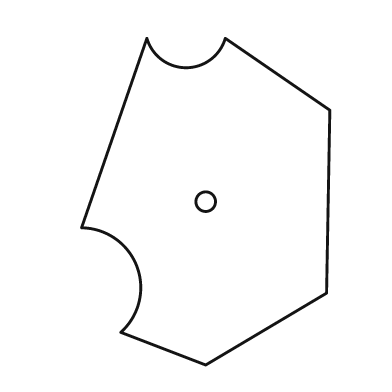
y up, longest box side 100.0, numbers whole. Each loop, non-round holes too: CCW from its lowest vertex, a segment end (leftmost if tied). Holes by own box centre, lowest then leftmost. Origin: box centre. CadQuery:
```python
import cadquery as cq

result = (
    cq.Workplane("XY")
    .moveTo(0.0, -50.0)
    .lineTo(37.0, -28.0)
    .lineTo(38.0, 28.0)
    .lineTo(6.0, 50.0)
    .threePointArc((-6.0, 41.0), (-18.0, 50.0))
    .lineTo(-38.0, -8.0)
    .threePointArc((-21.0, -20.0), (-26.0, -40.0))
    .close()
    .moveTo(0.0, 0.0)
    .circle(3.0)
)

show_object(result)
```